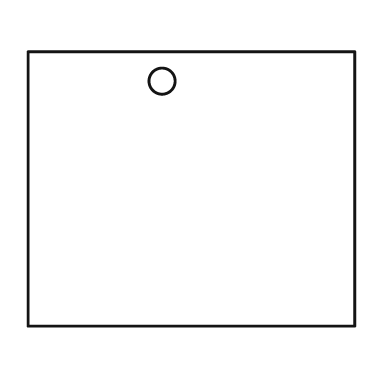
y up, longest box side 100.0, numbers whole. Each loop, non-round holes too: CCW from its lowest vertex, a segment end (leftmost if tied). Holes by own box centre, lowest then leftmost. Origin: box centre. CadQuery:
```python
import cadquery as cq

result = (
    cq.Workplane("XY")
    .moveTo(-50.0, -42.0)
    .lineTo(50.0, -42.0)
    .lineTo(50.0, 42.0)
    .lineTo(-50.0, 42.0)
    .close()
    .moveTo(-9.0, 33.0)
    .circle(4.0)
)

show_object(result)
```